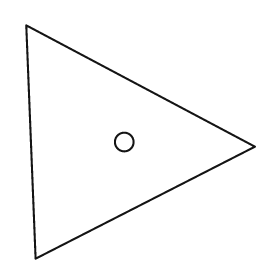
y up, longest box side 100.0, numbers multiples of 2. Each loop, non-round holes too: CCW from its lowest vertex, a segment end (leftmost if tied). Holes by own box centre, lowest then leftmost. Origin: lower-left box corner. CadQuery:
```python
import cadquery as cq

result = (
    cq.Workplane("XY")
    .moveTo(4.0, 0.0)
    .lineTo(98.0, 48.0)
    .lineTo(0.0, 100.0)
    .close()
    .moveTo(42.0, 50.0)
    .circle(4.0)
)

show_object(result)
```